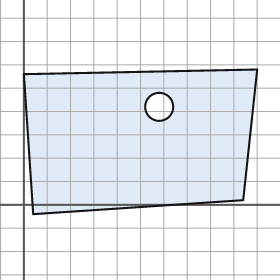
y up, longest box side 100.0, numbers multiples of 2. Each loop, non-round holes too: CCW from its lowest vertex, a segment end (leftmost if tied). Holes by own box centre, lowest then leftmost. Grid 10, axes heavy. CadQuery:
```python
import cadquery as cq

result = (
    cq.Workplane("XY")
    .moveTo(4.0, -4.0)
    .lineTo(94.0, 2.0)
    .lineTo(100.0, 58.0)
    .lineTo(0.0, 56.0)
    .close()
    .moveTo(58.0, 42.0)
    .circle(6.0)
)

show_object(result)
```